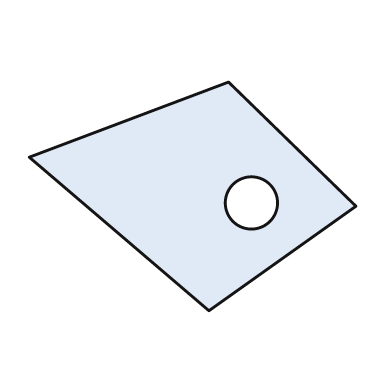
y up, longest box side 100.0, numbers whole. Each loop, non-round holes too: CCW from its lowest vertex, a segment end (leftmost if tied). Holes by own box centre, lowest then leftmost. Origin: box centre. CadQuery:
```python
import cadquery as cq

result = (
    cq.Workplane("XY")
    .moveTo(5.0, -35.0)
    .lineTo(50.0, -3.0)
    .lineTo(11.0, 35.0)
    .lineTo(-50.0, 12.0)
    .close()
    .moveTo(18.0, -2.0)
    .circle(8.0)
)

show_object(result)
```